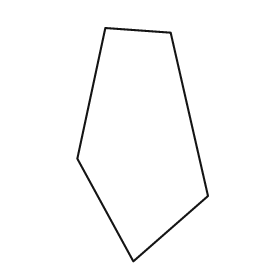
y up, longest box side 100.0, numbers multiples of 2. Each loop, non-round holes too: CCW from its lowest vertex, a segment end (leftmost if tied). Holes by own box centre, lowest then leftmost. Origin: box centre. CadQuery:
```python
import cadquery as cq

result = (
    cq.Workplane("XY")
    .moveTo(-4.0, -50.0)
    .lineTo(28.0, -22.0)
    .lineTo(12.0, 48.0)
    .lineTo(-16.0, 50.0)
    .lineTo(-28.0, -6.0)
    .close()
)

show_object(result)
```